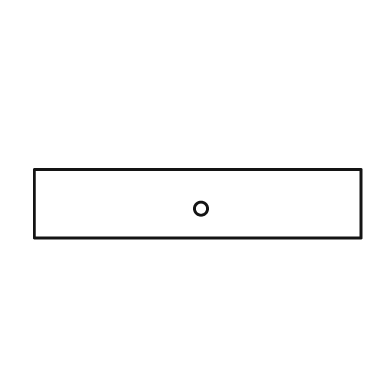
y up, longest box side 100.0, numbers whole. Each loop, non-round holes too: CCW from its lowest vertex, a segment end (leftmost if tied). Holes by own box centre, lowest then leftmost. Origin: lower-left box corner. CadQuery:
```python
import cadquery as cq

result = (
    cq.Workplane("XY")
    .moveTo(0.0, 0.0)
    .lineTo(100.0, 0.0)
    .lineTo(100.0, 21.0)
    .lineTo(0.0, 21.0)
    .close()
    .moveTo(51.0, 9.0)
    .circle(2.0)
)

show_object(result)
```